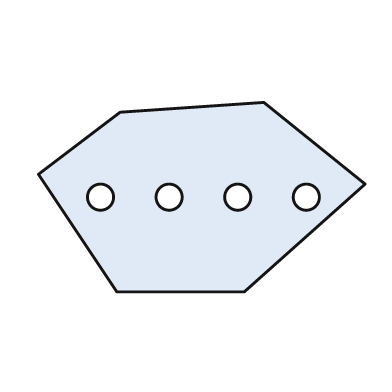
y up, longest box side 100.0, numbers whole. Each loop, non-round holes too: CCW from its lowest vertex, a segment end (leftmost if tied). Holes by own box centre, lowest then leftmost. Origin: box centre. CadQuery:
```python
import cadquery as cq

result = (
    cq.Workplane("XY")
    .moveTo(-26.0, -29.0)
    .lineTo(13.0, -29.0)
    .lineTo(50.0, 4.0)
    .lineTo(19.0, 29.0)
    .lineTo(-25.0, 26.0)
    .lineTo(-50.0, 7.0)
    .close()
    .moveTo(-31.0, 0.0)
    .circle(4.0)
    .moveTo(-10.0, 0.0)
    .circle(4.0)
    .moveTo(11.0, 0.0)
    .circle(4.0)
    .moveTo(32.0, 0.0)
    .circle(4.0)
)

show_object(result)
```